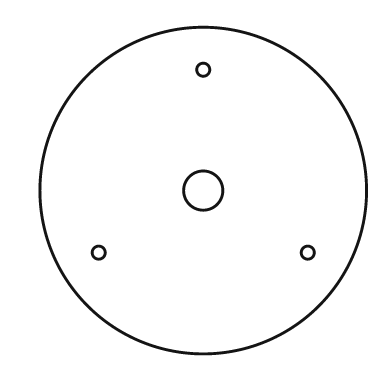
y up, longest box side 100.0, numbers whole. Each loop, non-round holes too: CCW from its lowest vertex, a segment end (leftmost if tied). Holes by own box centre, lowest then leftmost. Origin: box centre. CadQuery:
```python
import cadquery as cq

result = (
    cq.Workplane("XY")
    .moveTo(0.0, 0.0)
    .circle(50.0)
    .moveTo(-32.0, -19.0)
    .circle(2.0)
    .moveTo(32.0, -19.0)
    .circle(2.0)
    .moveTo(0.0, 0.0)
    .circle(6.0)
    .moveTo(0.0, 37.0)
    .circle(2.0)
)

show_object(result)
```